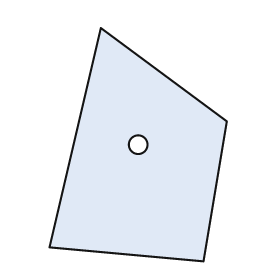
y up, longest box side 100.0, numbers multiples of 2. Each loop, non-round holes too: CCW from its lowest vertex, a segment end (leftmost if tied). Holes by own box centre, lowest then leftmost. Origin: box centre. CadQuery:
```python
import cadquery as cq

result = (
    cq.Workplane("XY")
    .moveTo(28.0, -50.0)
    .lineTo(38.0, 10.0)
    .lineTo(-16.0, 50.0)
    .lineTo(-38.0, -44.0)
    .close()
    .moveTo(0.0, 0.0)
    .circle(4.0)
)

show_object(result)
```